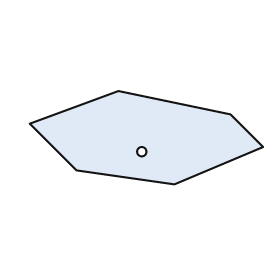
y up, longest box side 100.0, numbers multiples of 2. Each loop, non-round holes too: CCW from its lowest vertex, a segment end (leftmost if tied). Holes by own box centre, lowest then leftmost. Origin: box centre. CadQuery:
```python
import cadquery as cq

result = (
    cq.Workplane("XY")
    .moveTo(12.0, -20.0)
    .lineTo(50.0, -4.0)
    .lineTo(36.0, 10.0)
    .lineTo(-12.0, 20.0)
    .lineTo(-50.0, 6.0)
    .lineTo(-30.0, -14.0)
    .close()
    .moveTo(-2.0, -6.0)
    .circle(2.0)
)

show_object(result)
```